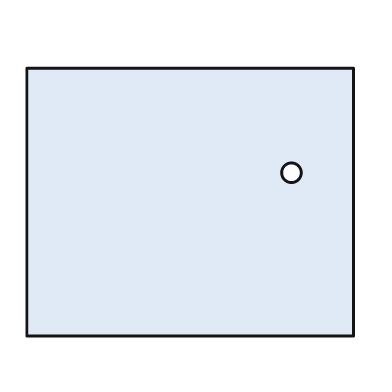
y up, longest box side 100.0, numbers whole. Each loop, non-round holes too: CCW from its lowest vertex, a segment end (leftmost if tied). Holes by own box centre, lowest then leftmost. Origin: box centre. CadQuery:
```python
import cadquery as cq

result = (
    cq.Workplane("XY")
    .moveTo(-50.0, -41.0)
    .lineTo(50.0, -41.0)
    .lineTo(50.0, 41.0)
    .lineTo(-50.0, 41.0)
    .close()
    .moveTo(31.0, 9.0)
    .circle(3.0)
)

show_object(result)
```